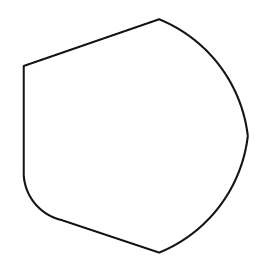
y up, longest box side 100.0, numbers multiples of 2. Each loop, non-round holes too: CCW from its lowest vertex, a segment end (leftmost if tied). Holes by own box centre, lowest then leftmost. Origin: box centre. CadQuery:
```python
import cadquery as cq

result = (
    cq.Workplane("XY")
    .moveTo(10.0, -50.0)
    .threePointArc((36.0, -30.0), (48.0, 0.0))
    .threePointArc((36.0, 30.0), (10.0, 50.0))
    .lineTo(-48.0, 30.0)
    .lineTo(-48.0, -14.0)
    .threePointArc((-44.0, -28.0), (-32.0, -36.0))
    .close()
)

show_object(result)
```